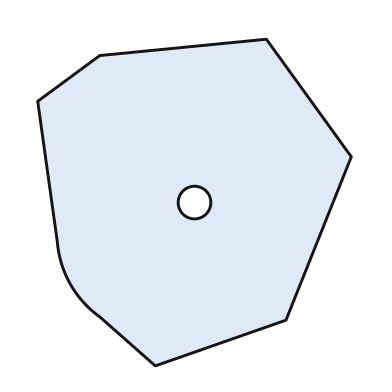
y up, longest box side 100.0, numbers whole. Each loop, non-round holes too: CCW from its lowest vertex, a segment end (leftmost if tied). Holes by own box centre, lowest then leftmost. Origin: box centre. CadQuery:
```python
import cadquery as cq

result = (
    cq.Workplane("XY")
    .moveTo(-12.0, -50.0)
    .lineTo(28.0, -36.0)
    .lineTo(48.0, 14.0)
    .lineTo(22.0, 50.0)
    .lineTo(-29.0, 45.0)
    .lineTo(-48.0, 31.0)
    .lineTo(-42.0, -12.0)
    .threePointArc((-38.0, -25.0), (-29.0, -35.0))
    .close()
    .moveTo(0.0, 0.0)
    .circle(5.0)
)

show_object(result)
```